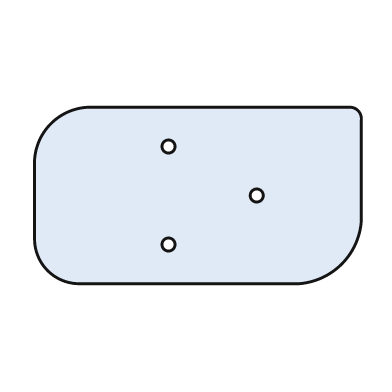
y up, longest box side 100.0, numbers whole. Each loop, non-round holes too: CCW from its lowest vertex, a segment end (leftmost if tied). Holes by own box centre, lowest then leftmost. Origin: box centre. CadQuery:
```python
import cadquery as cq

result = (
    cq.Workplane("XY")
    .moveTo(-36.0, -27.0)
    .lineTo(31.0, -27.0)
    .threePointArc((44.0, -21.0), (50.0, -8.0))
    .lineTo(50.0, 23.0)
    .threePointArc((49.0, 26.0), (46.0, 27.0))
    .lineTo(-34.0, 27.0)
    .threePointArc((-45.0, 22.0), (-50.0, 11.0))
    .lineTo(-50.0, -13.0)
    .threePointArc((-46.0, -23.0), (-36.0, -27.0))
    .close()
    .moveTo(-9.0, -15.0)
    .circle(2.0)
    .moveTo(18.0, 0.0)
    .circle(2.0)
    .moveTo(-9.0, 15.0)
    .circle(2.0)
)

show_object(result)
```